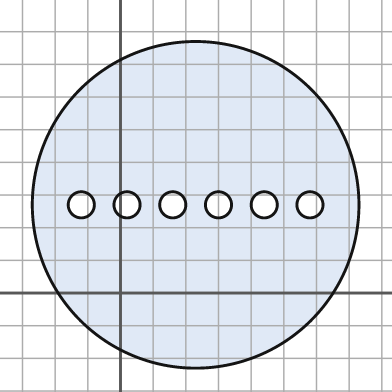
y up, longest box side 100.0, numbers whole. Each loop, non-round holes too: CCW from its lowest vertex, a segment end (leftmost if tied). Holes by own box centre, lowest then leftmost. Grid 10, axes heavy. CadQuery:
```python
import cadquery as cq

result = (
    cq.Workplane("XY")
    .moveTo(23.0, 27.0)
    .circle(50.0)
    .moveTo(-12.0, 27.0)
    .circle(4.0)
    .moveTo(2.0, 27.0)
    .circle(4.0)
    .moveTo(16.0, 27.0)
    .circle(4.0)
    .moveTo(30.0, 27.0)
    .circle(4.0)
    .moveTo(44.0, 27.0)
    .circle(4.0)
    .moveTo(58.0, 27.0)
    .circle(4.0)
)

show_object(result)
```